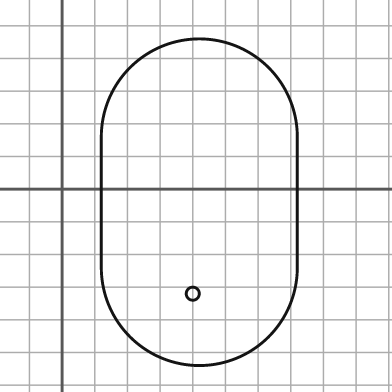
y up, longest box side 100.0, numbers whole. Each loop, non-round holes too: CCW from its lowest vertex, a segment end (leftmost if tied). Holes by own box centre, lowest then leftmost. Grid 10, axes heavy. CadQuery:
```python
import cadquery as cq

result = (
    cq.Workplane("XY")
    .moveTo(12.0, -24.0)
    .threePointArc((42.0, -54.0), (72.0, -24.0))
    .lineTo(72.0, 16.0)
    .threePointArc((42.0, 46.0), (12.0, 16.0))
    .close()
    .moveTo(40.0, -32.0)
    .circle(2.0)
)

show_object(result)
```